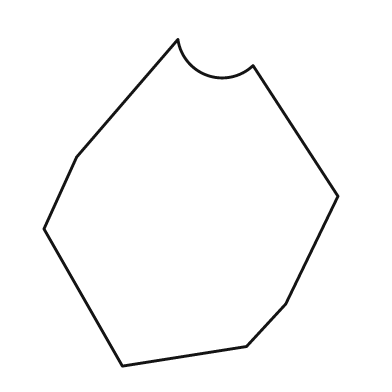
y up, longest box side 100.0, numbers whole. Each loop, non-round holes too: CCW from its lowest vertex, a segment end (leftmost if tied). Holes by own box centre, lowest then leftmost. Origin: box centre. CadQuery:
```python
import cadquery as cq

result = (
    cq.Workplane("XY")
    .moveTo(-21.0, -50.0)
    .lineTo(17.0, -44.0)
    .lineTo(29.0, -31.0)
    .lineTo(45.0, 2.0)
    .lineTo(19.0, 42.0)
    .threePointArc((5.0, 39.0), (-4.0, 50.0))
    .lineTo(-35.0, 14.0)
    .lineTo(-45.0, -8.0)
    .close()
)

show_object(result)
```